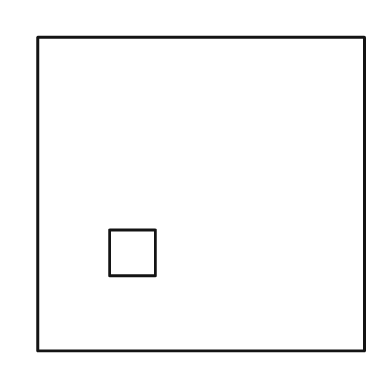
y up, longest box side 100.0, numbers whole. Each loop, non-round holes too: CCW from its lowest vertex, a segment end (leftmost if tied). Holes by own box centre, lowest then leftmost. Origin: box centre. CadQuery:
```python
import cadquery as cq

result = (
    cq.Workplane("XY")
    .moveTo(-50.0, -48.0)
    .lineTo(50.0, -48.0)
    .lineTo(50.0, 48.0)
    .lineTo(-50.0, 48.0)
    .close()
    .moveTo(-28.0, -25.0)
    .lineTo(-14.0, -25.0)
    .lineTo(-14.0, -11.0)
    .lineTo(-28.0, -11.0)
    .close()
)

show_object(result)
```